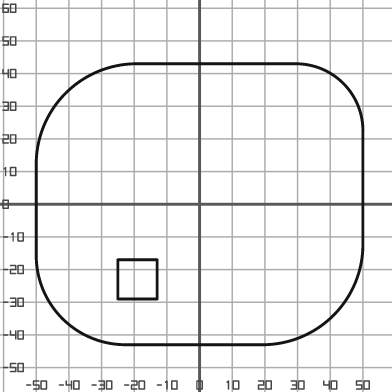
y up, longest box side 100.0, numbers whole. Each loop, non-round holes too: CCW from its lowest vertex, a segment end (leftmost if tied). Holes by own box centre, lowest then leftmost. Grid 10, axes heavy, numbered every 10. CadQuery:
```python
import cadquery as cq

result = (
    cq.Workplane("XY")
    .moveTo(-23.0, -43.0)
    .lineTo(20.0, -43.0)
    .threePointArc((41.0, -34.0), (50.0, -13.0))
    .lineTo(50.0, 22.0)
    .threePointArc((44.0, 37.0), (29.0, 43.0))
    .lineTo(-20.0, 43.0)
    .threePointArc((-41.0, 34.0), (-50.0, 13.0))
    .lineTo(-50.0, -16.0)
    .threePointArc((-42.0, -35.0), (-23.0, -43.0))
    .close()
    .moveTo(-25.0, -29.0)
    .lineTo(-13.0, -29.0)
    .lineTo(-13.0, -17.0)
    .lineTo(-25.0, -17.0)
    .close()
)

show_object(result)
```